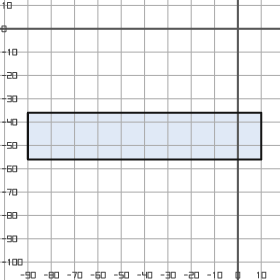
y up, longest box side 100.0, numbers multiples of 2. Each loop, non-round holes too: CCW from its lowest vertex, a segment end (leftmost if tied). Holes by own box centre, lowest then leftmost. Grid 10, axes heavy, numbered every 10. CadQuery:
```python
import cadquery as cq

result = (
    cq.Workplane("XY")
    .moveTo(-90.0, -56.0)
    .lineTo(10.0, -56.0)
    .lineTo(10.0, -36.0)
    .lineTo(-90.0, -36.0)
    .close()
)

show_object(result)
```